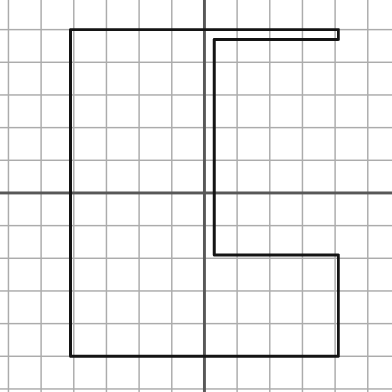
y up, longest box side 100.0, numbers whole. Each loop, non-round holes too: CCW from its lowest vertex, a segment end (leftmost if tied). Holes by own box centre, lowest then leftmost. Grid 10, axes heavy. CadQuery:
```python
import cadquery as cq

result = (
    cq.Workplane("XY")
    .moveTo(-41.0, -50.0)
    .lineTo(41.0, -50.0)
    .lineTo(41.0, -19.0)
    .lineTo(3.0, -19.0)
    .lineTo(3.0, 47.0)
    .lineTo(41.0, 47.0)
    .lineTo(41.0, 50.0)
    .lineTo(-41.0, 50.0)
    .close()
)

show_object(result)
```